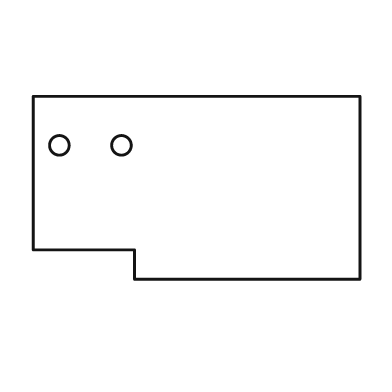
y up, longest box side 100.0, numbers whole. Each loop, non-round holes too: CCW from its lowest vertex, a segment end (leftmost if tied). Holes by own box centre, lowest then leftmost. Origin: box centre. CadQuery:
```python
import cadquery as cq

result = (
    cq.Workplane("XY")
    .moveTo(-19.0, -28.0)
    .lineTo(50.0, -28.0)
    .lineTo(50.0, 28.0)
    .lineTo(-50.0, 28.0)
    .lineTo(-50.0, -19.0)
    .lineTo(-19.0, -19.0)
    .close()
    .moveTo(-42.0, 13.0)
    .circle(3.0)
    .moveTo(-23.0, 13.0)
    .circle(3.0)
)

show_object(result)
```